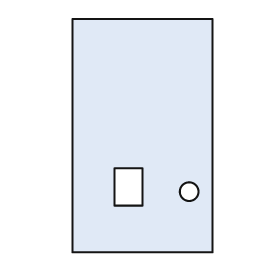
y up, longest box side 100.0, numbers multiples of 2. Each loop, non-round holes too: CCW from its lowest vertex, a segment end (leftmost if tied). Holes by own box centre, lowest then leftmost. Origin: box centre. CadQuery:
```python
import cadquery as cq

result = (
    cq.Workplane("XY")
    .moveTo(-30.0, -50.0)
    .lineTo(30.0, -50.0)
    .lineTo(30.0, 50.0)
    .lineTo(-30.0, 50.0)
    .close()
    .moveTo(20.0, -24.0)
    .circle(4.0)
    .moveTo(-12.0, -30.0)
    .lineTo(0.0, -30.0)
    .lineTo(0.0, -14.0)
    .lineTo(-12.0, -14.0)
    .close()
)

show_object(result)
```